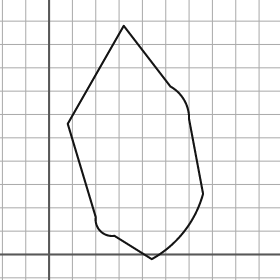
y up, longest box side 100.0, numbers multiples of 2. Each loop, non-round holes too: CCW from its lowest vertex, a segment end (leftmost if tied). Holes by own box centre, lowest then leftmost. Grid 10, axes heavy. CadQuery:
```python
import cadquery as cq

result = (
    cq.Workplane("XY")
    .moveTo(44.0, -2.0)
    .threePointArc((58.0, 10.0), (66.0, 26.0))
    .lineTo(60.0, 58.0)
    .threePointArc((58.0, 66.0), (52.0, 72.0))
    .lineTo(32.0, 98.0)
    .lineTo(8.0, 56.0)
    .lineTo(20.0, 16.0)
    .threePointArc((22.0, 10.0), (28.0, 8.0))
    .close()
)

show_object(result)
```